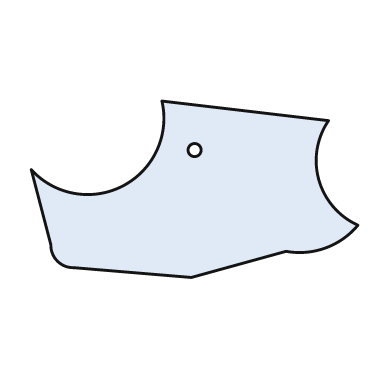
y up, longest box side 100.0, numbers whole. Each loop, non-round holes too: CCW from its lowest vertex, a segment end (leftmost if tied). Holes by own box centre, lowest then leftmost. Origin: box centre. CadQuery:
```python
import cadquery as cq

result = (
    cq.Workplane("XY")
    .moveTo(-1.0, -27.0)
    .lineTo(28.0, -19.0)
    .threePointArc((40.0, -18.0), (50.0, -11.0))
    .threePointArc((38.0, 3.0), (41.0, 21.0))
    .lineTo(-10.0, 27.0)
    .threePointArc((-22.0, 1.0), (-50.0, 6.0))
    .lineTo(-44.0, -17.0)
    .threePointArc((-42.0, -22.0), (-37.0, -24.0))
    .close()
    .moveTo(0.0, 12.0)
    .circle(2.0)
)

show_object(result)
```